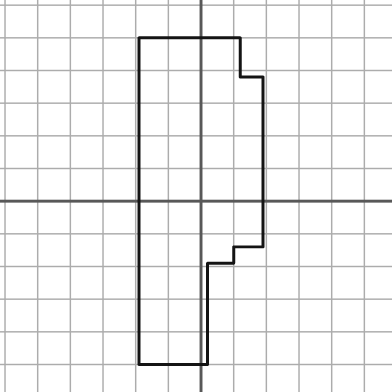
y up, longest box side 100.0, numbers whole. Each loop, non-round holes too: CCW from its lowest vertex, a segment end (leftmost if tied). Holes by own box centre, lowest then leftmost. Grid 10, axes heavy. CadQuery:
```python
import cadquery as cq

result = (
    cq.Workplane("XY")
    .moveTo(-19.0, -50.0)
    .lineTo(2.0, -50.0)
    .lineTo(2.0, -19.0)
    .lineTo(10.0, -19.0)
    .lineTo(10.0, -14.0)
    .lineTo(19.0, -14.0)
    .lineTo(19.0, 38.0)
    .lineTo(12.0, 38.0)
    .lineTo(12.0, 50.0)
    .lineTo(-19.0, 50.0)
    .close()
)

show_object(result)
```